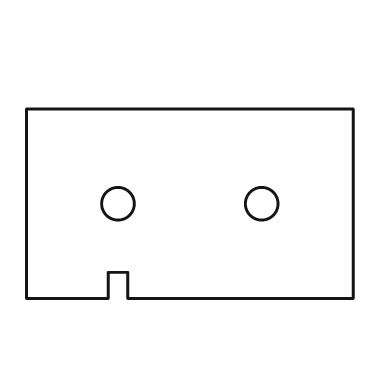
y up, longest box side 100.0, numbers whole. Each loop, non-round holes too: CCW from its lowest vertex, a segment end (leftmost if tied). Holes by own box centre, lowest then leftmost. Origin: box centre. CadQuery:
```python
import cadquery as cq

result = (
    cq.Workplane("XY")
    .moveTo(-50.0, -29.0)
    .lineTo(-25.0, -29.0)
    .lineTo(-25.0, -21.0)
    .lineTo(-19.0, -21.0)
    .lineTo(-19.0, -29.0)
    .lineTo(50.0, -29.0)
    .lineTo(50.0, 29.0)
    .lineTo(-50.0, 29.0)
    .close()
    .moveTo(-22.0, 0.0)
    .circle(5.0)
    .moveTo(22.0, 0.0)
    .circle(5.0)
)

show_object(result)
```